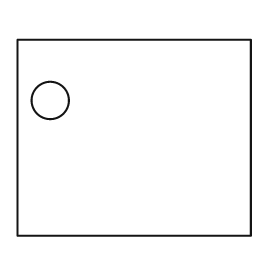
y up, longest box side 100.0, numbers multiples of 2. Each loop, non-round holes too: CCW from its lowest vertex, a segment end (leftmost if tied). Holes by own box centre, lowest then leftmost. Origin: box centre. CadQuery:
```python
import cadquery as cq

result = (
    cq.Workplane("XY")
    .moveTo(-50.0, -42.0)
    .lineTo(50.0, -42.0)
    .lineTo(50.0, 42.0)
    .lineTo(-50.0, 42.0)
    .close()
    .moveTo(-36.0, 16.0)
    .circle(8.0)
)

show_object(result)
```